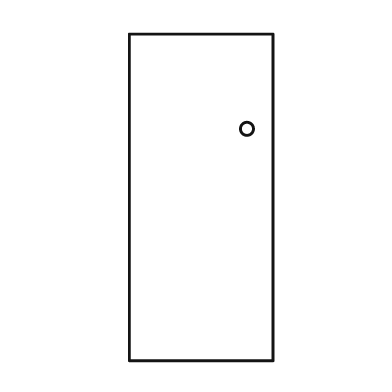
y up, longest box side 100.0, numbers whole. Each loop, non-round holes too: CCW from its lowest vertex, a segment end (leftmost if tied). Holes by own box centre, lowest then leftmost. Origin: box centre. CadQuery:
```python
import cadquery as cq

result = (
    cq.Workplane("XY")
    .moveTo(-22.0, -50.0)
    .lineTo(22.0, -50.0)
    .lineTo(22.0, 50.0)
    .lineTo(-22.0, 50.0)
    .close()
    .moveTo(14.0, 21.0)
    .circle(2.0)
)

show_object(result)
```